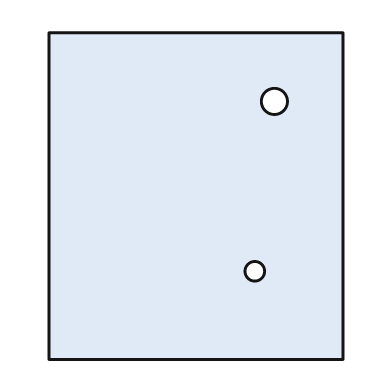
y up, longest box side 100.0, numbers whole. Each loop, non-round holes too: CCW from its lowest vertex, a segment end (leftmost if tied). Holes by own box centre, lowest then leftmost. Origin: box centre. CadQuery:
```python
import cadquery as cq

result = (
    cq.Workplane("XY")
    .moveTo(-45.0, -50.0)
    .lineTo(45.0, -50.0)
    .lineTo(45.0, 50.0)
    .lineTo(-45.0, 50.0)
    .close()
    .moveTo(18.0, -23.0)
    .circle(3.0)
    .moveTo(24.0, 29.0)
    .circle(4.0)
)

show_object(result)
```